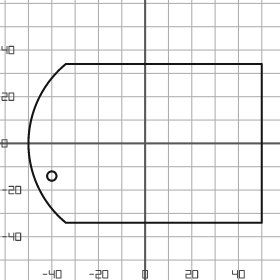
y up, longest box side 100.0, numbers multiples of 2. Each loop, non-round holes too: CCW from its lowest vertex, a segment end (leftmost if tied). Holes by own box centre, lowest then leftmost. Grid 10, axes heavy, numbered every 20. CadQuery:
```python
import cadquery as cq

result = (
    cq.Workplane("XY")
    .moveTo(-34.0, -34.0)
    .lineTo(50.0, -34.0)
    .lineTo(50.0, 34.0)
    .lineTo(-34.0, 34.0)
    .threePointArc((-50.0, 0.0), (-34.0, -34.0))
    .close()
    .moveTo(-40.0, -14.0)
    .circle(2.0)
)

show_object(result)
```